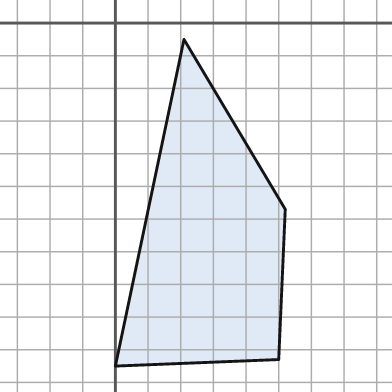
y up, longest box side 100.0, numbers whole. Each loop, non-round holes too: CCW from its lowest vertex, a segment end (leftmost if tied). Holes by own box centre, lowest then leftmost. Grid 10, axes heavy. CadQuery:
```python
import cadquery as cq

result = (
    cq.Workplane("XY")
    .moveTo(0.0, -105.0)
    .lineTo(50.0, -103.0)
    .lineTo(52.0, -57.0)
    .lineTo(21.0, -5.0)
    .close()
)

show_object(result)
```